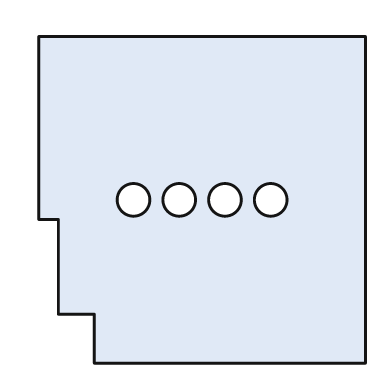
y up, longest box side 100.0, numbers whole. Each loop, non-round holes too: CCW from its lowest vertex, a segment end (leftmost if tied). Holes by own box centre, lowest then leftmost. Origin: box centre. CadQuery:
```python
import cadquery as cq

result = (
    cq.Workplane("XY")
    .moveTo(-33.0, -50.0)
    .lineTo(50.0, -50.0)
    .lineTo(50.0, 50.0)
    .lineTo(-50.0, 50.0)
    .lineTo(-50.0, -6.0)
    .lineTo(-44.0, -6.0)
    .lineTo(-44.0, -35.0)
    .lineTo(-33.0, -35.0)
    .close()
    .moveTo(-21.0, 0.0)
    .circle(5.0)
    .moveTo(-7.0, 0.0)
    .circle(5.0)
    .moveTo(7.0, 0.0)
    .circle(5.0)
    .moveTo(21.0, 0.0)
    .circle(5.0)
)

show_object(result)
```